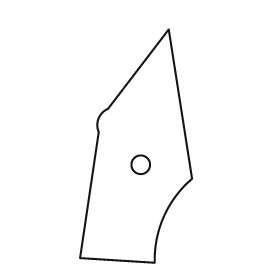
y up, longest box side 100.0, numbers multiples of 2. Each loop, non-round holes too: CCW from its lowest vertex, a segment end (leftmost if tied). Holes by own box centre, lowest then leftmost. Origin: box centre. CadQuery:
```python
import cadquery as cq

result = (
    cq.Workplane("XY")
    .moveTo(8.0, -50.0)
    .threePointArc((12.0, -30.0), (24.0, -14.0))
    .lineTo(14.0, 50.0)
    .lineTo(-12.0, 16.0)
    .threePointArc((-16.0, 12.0), (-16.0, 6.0))
    .lineTo(-24.0, -48.0)
    .close()
    .moveTo(2.0, -8.0)
    .circle(4.0)
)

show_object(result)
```